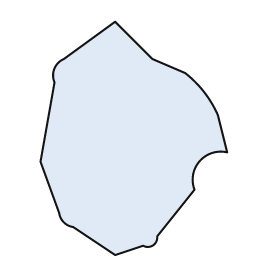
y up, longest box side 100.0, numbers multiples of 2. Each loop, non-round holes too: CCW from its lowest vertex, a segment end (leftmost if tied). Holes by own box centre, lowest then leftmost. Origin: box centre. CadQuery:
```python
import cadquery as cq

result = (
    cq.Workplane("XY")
    .moveTo(-8.0, -50.0)
    .lineTo(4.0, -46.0)
    .threePointArc((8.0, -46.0), (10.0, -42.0))
    .lineTo(26.0, -22.0)
    .threePointArc((28.0, -10.0), (40.0, -6.0))
    .lineTo(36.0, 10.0)
    .threePointArc((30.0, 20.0), (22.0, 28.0))
    .lineTo(8.0, 34.0)
    .lineTo(-8.0, 50.0)
    .lineTo(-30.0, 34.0)
    .threePointArc((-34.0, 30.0), (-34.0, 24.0))
    .lineTo(-40.0, -10.0)
    .lineTo(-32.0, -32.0)
    .threePointArc((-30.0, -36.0), (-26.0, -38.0))
    .close()
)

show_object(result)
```